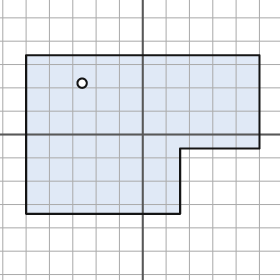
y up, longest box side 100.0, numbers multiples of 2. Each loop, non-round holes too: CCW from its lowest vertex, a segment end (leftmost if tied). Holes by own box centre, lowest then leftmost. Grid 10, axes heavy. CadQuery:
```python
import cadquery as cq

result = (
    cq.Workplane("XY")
    .moveTo(-50.0, -34.0)
    .lineTo(16.0, -34.0)
    .lineTo(16.0, -6.0)
    .lineTo(50.0, -6.0)
    .lineTo(50.0, 34.0)
    .lineTo(-50.0, 34.0)
    .close()
    .moveTo(-26.0, 22.0)
    .circle(2.0)
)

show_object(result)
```